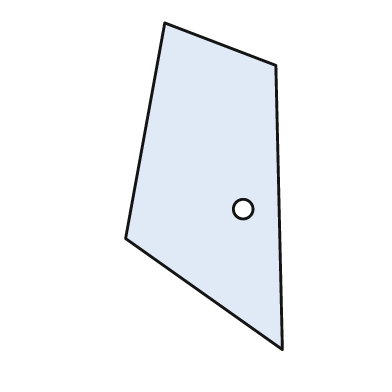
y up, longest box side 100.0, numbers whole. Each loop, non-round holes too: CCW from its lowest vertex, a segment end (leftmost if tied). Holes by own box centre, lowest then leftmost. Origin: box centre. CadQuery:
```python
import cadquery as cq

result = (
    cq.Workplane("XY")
    .moveTo(24.0, -50.0)
    .lineTo(22.0, 37.0)
    .lineTo(-12.0, 50.0)
    .lineTo(-24.0, -16.0)
    .close()
    .moveTo(12.0, -7.0)
    .circle(3.0)
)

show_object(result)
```